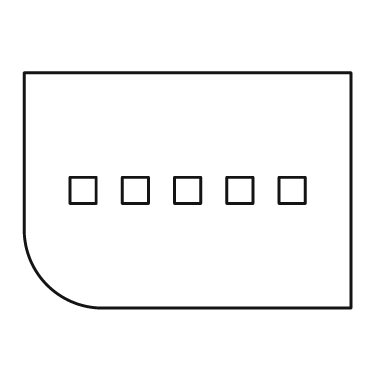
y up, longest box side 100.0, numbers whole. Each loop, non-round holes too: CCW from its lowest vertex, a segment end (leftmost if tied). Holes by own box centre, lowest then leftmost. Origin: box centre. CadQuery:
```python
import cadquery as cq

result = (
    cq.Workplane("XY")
    .moveTo(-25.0, -36.0)
    .lineTo(50.0, -36.0)
    .lineTo(50.0, 36.0)
    .lineTo(-50.0, 36.0)
    .lineTo(-50.0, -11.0)
    .threePointArc((-43.0, -29.0), (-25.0, -36.0))
    .close()
    .moveTo(-36.0, -4.0)
    .lineTo(-28.0, -4.0)
    .lineTo(-28.0, 4.0)
    .lineTo(-36.0, 4.0)
    .close()
    .moveTo(-20.0, -4.0)
    .lineTo(-12.0, -4.0)
    .lineTo(-12.0, 4.0)
    .lineTo(-20.0, 4.0)
    .close()
    .moveTo(-4.0, -4.0)
    .lineTo(4.0, -4.0)
    .lineTo(4.0, 4.0)
    .lineTo(-4.0, 4.0)
    .close()
    .moveTo(12.0, -4.0)
    .lineTo(20.0, -4.0)
    .lineTo(20.0, 4.0)
    .lineTo(12.0, 4.0)
    .close()
    .moveTo(28.0, -4.0)
    .lineTo(36.0, -4.0)
    .lineTo(36.0, 4.0)
    .lineTo(28.0, 4.0)
    .close()
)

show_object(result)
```